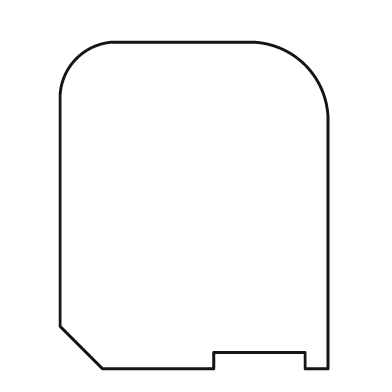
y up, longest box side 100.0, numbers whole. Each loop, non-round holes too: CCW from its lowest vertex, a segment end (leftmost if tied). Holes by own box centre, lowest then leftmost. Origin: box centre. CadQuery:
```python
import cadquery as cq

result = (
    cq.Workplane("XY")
    .moveTo(-28.0, -50.0)
    .lineTo(6.0, -50.0)
    .lineTo(6.0, -45.0)
    .lineTo(34.0, -45.0)
    .lineTo(34.0, -50.0)
    .lineTo(41.0, -50.0)
    .lineTo(41.0, 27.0)
    .threePointArc((34.0, 43.0), (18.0, 50.0))
    .lineTo(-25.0, 50.0)
    .threePointArc((-36.0, 45.0), (-41.0, 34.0))
    .lineTo(-41.0, -37.0)
    .close()
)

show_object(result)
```